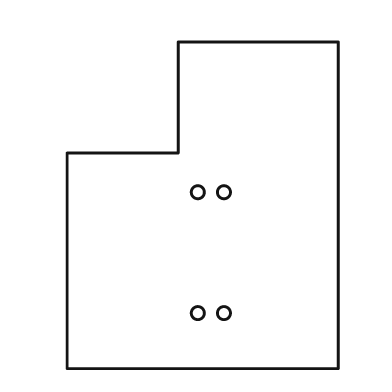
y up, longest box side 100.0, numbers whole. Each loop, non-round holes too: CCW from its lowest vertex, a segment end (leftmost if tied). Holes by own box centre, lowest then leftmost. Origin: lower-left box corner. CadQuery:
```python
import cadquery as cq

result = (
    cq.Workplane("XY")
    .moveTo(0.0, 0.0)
    .lineTo(83.0, 0.0)
    .lineTo(83.0, 100.0)
    .lineTo(34.0, 100.0)
    .lineTo(34.0, 66.0)
    .lineTo(0.0, 66.0)
    .close()
    .moveTo(40.0, 17.0)
    .circle(2.0)
    .moveTo(48.0, 17.0)
    .circle(2.0)
    .moveTo(40.0, 54.0)
    .circle(2.0)
    .moveTo(48.0, 54.0)
    .circle(2.0)
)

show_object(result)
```